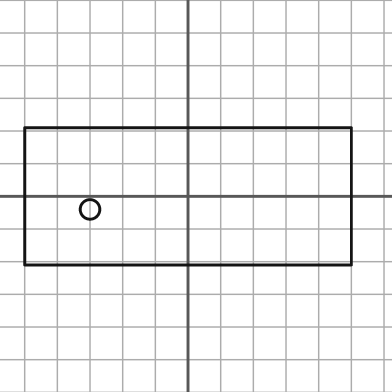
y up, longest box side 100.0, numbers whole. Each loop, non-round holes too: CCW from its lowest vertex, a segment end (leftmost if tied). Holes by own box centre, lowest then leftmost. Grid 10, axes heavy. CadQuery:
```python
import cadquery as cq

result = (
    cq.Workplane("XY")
    .moveTo(-50.0, -21.0)
    .lineTo(50.0, -21.0)
    .lineTo(50.0, 21.0)
    .lineTo(-50.0, 21.0)
    .close()
    .moveTo(-30.0, -4.0)
    .circle(3.0)
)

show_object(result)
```